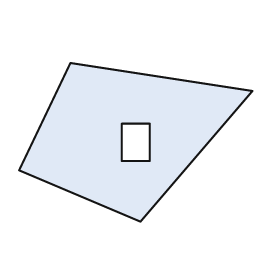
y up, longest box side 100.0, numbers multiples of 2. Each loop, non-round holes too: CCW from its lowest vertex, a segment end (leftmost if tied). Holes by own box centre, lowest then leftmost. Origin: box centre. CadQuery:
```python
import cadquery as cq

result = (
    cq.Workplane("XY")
    .moveTo(2.0, -34.0)
    .lineTo(50.0, 22.0)
    .lineTo(-28.0, 34.0)
    .lineTo(-50.0, -12.0)
    .close()
    .moveTo(-6.0, -8.0)
    .lineTo(6.0, -8.0)
    .lineTo(6.0, 8.0)
    .lineTo(-6.0, 8.0)
    .close()
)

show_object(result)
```